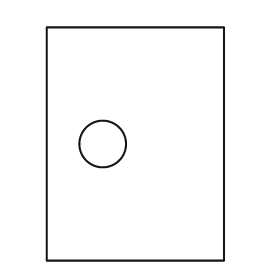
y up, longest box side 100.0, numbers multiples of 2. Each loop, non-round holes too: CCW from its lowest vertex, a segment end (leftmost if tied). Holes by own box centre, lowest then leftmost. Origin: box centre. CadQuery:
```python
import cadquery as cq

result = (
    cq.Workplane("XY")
    .moveTo(-38.0, -50.0)
    .lineTo(38.0, -50.0)
    .lineTo(38.0, 50.0)
    .lineTo(-38.0, 50.0)
    .close()
    .moveTo(-14.0, 0.0)
    .circle(10.0)
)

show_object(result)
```